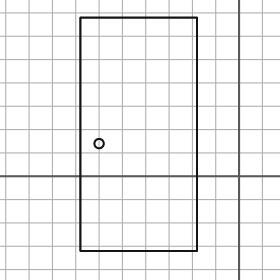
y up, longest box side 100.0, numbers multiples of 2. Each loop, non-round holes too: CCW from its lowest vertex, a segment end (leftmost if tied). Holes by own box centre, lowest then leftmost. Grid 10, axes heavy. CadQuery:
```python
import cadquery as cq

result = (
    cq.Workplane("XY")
    .moveTo(-68.0, -32.0)
    .lineTo(-18.0, -32.0)
    .lineTo(-18.0, 68.0)
    .lineTo(-68.0, 68.0)
    .close()
    .moveTo(-60.0, 14.0)
    .circle(2.0)
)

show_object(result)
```